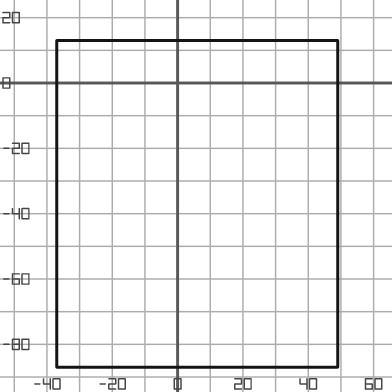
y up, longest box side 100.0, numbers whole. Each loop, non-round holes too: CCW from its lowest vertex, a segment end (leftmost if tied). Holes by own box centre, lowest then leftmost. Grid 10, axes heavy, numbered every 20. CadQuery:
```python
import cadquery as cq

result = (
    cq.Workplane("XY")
    .moveTo(-37.0, -87.0)
    .lineTo(49.0, -87.0)
    .lineTo(49.0, 13.0)
    .lineTo(-37.0, 13.0)
    .close()
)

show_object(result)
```